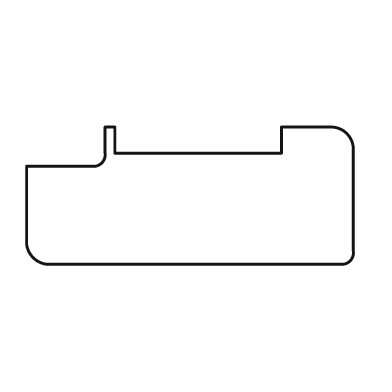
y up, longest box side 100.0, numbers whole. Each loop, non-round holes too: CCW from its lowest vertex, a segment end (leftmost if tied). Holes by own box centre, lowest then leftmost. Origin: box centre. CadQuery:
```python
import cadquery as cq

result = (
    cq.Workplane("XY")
    .moveTo(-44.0, -21.0)
    .lineTo(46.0, -21.0)
    .threePointArc((49.0, -20.0), (50.0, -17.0))
    .lineTo(50.0, 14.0)
    .threePointArc((48.0, 19.0), (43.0, 21.0))
    .lineTo(28.0, 21.0)
    .lineTo(28.0, 13.0)
    .lineTo(-23.0, 13.0)
    .lineTo(-23.0, 21.0)
    .lineTo(-26.0, 21.0)
    .lineTo(-26.0, 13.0)
    .threePointArc((-27.0, 10.0), (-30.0, 9.0))
    .lineTo(-50.0, 9.0)
    .lineTo(-50.0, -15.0)
    .threePointArc((-48.0, -19.0), (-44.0, -21.0))
    .close()
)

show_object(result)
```